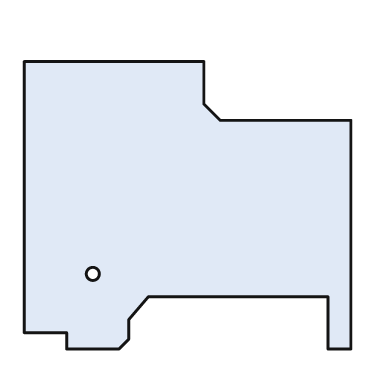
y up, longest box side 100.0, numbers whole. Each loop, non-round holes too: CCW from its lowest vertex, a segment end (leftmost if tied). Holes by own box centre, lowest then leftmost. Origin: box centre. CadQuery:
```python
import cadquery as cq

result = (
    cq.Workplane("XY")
    .moveTo(-37.0, -44.0)
    .lineTo(-21.0, -44.0)
    .lineTo(-18.0, -41.0)
    .lineTo(-18.0, -35.0)
    .lineTo(-12.0, -28.0)
    .lineTo(43.0, -28.0)
    .lineTo(43.0, -44.0)
    .lineTo(50.0, -44.0)
    .lineTo(50.0, 26.0)
    .lineTo(10.0, 26.0)
    .lineTo(5.0, 31.0)
    .lineTo(5.0, 44.0)
    .lineTo(-50.0, 44.0)
    .lineTo(-50.0, -39.0)
    .lineTo(-37.0, -39.0)
    .close()
    .moveTo(-29.0, -21.0)
    .circle(2.0)
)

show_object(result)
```